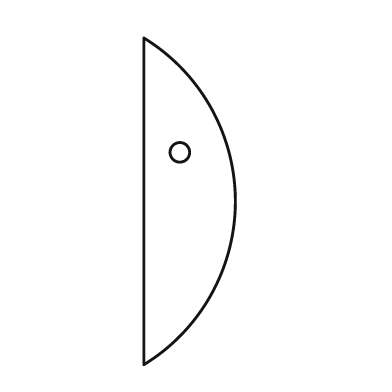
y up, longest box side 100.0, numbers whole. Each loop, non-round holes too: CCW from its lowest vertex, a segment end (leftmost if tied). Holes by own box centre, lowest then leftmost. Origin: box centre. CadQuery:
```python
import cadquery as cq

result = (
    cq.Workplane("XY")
    .moveTo(-14.0, -50.0)
    .threePointArc((14.0, 0.0), (-14.0, 50.0))
    .close()
    .moveTo(-3.0, 15.0)
    .circle(3.0)
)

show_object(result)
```